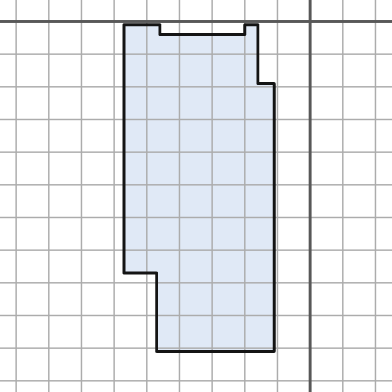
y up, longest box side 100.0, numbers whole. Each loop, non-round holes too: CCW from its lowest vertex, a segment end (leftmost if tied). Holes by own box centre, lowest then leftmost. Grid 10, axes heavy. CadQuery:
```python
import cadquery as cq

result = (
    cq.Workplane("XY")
    .moveTo(-47.0, -101.0)
    .lineTo(-11.0, -101.0)
    .lineTo(-11.0, -19.0)
    .lineTo(-16.0, -19.0)
    .lineTo(-16.0, -1.0)
    .lineTo(-20.0, -1.0)
    .lineTo(-20.0, -4.0)
    .lineTo(-46.0, -4.0)
    .lineTo(-46.0, -1.0)
    .lineTo(-57.0, -1.0)
    .lineTo(-57.0, -77.0)
    .lineTo(-47.0, -77.0)
    .close()
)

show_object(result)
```